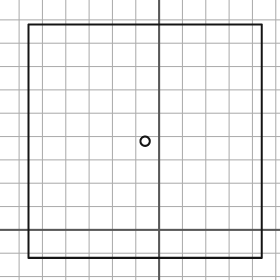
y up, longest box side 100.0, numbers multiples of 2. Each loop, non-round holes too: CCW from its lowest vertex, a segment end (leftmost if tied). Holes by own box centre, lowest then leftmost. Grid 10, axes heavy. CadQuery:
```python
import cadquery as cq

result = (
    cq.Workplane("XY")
    .moveTo(-56.0, -12.0)
    .lineTo(44.0, -12.0)
    .lineTo(44.0, 88.0)
    .lineTo(-56.0, 88.0)
    .close()
    .moveTo(-6.0, 38.0)
    .circle(2.0)
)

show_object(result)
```